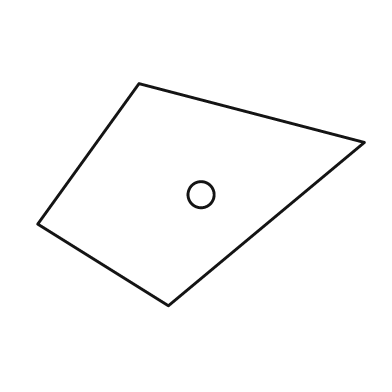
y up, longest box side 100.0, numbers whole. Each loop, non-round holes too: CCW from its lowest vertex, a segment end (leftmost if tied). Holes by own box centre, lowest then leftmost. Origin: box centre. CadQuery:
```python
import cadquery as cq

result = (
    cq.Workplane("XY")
    .moveTo(-10.0, -34.0)
    .lineTo(50.0, 16.0)
    .lineTo(-19.0, 34.0)
    .lineTo(-50.0, -9.0)
    .close()
    .moveTo(0.0, 0.0)
    .circle(4.0)
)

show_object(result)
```